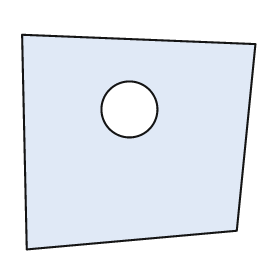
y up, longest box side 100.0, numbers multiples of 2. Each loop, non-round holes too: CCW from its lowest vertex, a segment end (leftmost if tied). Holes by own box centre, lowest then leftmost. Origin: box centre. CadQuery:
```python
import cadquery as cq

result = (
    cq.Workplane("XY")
    .moveTo(-48.0, -46.0)
    .lineTo(42.0, -38.0)
    .lineTo(50.0, 42.0)
    .lineTo(-50.0, 46.0)
    .close()
    .moveTo(-4.0, 14.0)
    .circle(12.0)
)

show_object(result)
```